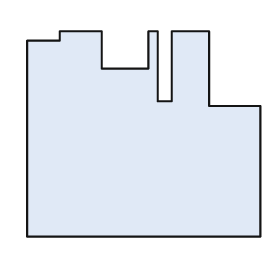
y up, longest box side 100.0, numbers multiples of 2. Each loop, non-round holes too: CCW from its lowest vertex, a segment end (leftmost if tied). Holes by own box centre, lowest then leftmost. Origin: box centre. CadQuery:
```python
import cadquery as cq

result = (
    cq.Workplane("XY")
    .moveTo(-50.0, -44.0)
    .lineTo(50.0, -44.0)
    .lineTo(50.0, 12.0)
    .lineTo(28.0, 12.0)
    .lineTo(28.0, 44.0)
    .lineTo(12.0, 44.0)
    .lineTo(12.0, 14.0)
    .lineTo(6.0, 14.0)
    .lineTo(6.0, 44.0)
    .lineTo(2.0, 44.0)
    .lineTo(2.0, 28.0)
    .lineTo(-18.0, 28.0)
    .lineTo(-18.0, 44.0)
    .lineTo(-36.0, 44.0)
    .lineTo(-36.0, 40.0)
    .lineTo(-50.0, 40.0)
    .close()
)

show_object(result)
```